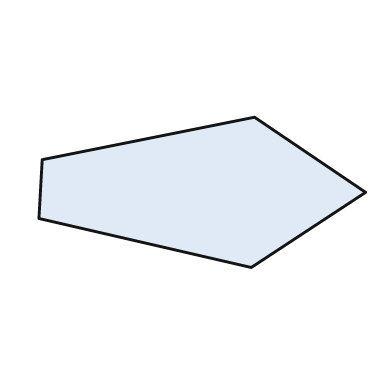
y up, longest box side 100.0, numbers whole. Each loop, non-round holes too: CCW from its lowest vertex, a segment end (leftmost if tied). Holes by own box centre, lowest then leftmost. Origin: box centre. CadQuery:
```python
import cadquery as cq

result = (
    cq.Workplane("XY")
    .moveTo(15.0, -23.0)
    .lineTo(50.0, 0.0)
    .lineTo(16.0, 23.0)
    .lineTo(-49.0, 10.0)
    .lineTo(-50.0, -8.0)
    .close()
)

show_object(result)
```